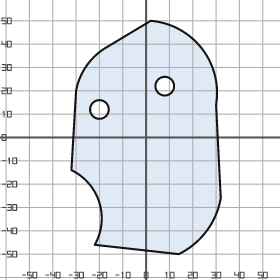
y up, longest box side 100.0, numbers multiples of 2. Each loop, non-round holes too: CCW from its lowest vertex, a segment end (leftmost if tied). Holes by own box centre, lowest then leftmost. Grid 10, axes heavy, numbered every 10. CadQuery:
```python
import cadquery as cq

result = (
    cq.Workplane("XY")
    .moveTo(14.0, -50.0)
    .threePointArc((26.0, -40.0), (32.0, -26.0))
    .lineTo(30.0, 14.0)
    .threePointArc((24.0, 38.0), (2.0, 50.0))
    .lineTo(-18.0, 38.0)
    .threePointArc((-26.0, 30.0), (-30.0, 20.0))
    .lineTo(-32.0, -14.0)
    .threePointArc((-20.0, -28.0), (-22.0, -46.0))
    .close()
    .moveTo(-20.0, 12.0)
    .circle(4.0)
    .moveTo(8.0, 22.0)
    .circle(4.0)
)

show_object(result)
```